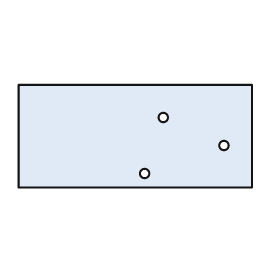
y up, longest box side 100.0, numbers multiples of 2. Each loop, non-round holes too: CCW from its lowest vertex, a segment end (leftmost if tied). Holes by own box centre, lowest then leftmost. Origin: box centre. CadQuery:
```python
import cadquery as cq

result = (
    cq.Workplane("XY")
    .moveTo(-50.0, -22.0)
    .lineTo(50.0, -22.0)
    .lineTo(50.0, 22.0)
    .lineTo(-50.0, 22.0)
    .close()
    .moveTo(4.0, -16.0)
    .circle(2.0)
    .moveTo(38.0, -4.0)
    .circle(2.0)
    .moveTo(12.0, 8.0)
    .circle(2.0)
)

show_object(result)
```